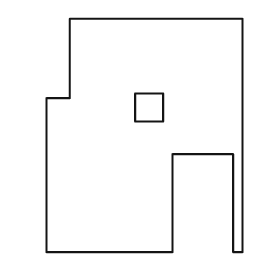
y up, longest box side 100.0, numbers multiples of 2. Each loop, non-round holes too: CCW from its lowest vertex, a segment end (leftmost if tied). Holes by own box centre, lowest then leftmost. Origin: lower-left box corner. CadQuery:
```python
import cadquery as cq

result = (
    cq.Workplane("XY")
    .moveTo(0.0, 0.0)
    .lineTo(54.0, 0.0)
    .lineTo(54.0, 42.0)
    .lineTo(80.0, 42.0)
    .lineTo(80.0, 0.0)
    .lineTo(84.0, 0.0)
    .lineTo(84.0, 100.0)
    .lineTo(10.0, 100.0)
    .lineTo(10.0, 66.0)
    .lineTo(0.0, 66.0)
    .close()
    .moveTo(38.0, 56.0)
    .lineTo(50.0, 56.0)
    .lineTo(50.0, 68.0)
    .lineTo(38.0, 68.0)
    .close()
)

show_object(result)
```